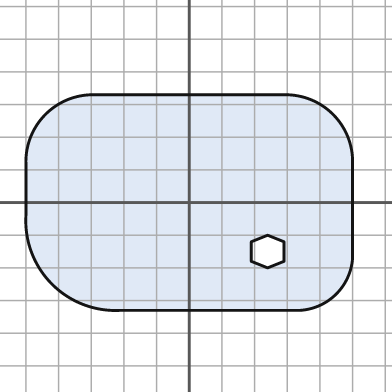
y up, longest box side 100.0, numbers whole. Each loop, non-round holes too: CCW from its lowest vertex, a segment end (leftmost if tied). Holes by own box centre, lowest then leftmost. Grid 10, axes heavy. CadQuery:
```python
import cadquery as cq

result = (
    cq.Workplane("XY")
    .moveTo(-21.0, -33.0)
    .lineTo(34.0, -33.0)
    .threePointArc((45.0, -28.0), (50.0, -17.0))
    .lineTo(50.0, 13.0)
    .threePointArc((44.0, 27.0), (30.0, 33.0))
    .lineTo(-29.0, 33.0)
    .threePointArc((-44.0, 27.0), (-50.0, 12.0))
    .lineTo(-50.0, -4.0)
    .threePointArc((-42.0, -25.0), (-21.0, -33.0))
    .close()
    .moveTo(24.0, -20.0)
    .lineTo(29.0, -18.0)
    .lineTo(29.0, -12.0)
    .lineTo(24.0, -10.0)
    .lineTo(19.0, -12.0)
    .lineTo(19.0, -18.0)
    .close()
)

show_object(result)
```